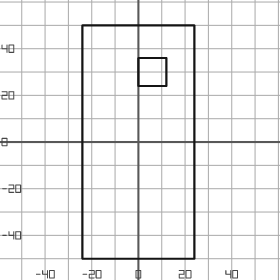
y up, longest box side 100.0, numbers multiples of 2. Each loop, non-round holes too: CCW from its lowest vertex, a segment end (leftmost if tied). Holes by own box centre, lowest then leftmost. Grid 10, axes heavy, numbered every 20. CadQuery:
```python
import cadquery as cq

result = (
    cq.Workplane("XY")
    .moveTo(-24.0, -50.0)
    .lineTo(24.0, -50.0)
    .lineTo(24.0, 50.0)
    .lineTo(-24.0, 50.0)
    .close()
    .moveTo(0.0, 24.0)
    .lineTo(12.0, 24.0)
    .lineTo(12.0, 36.0)
    .lineTo(0.0, 36.0)
    .close()
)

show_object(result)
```